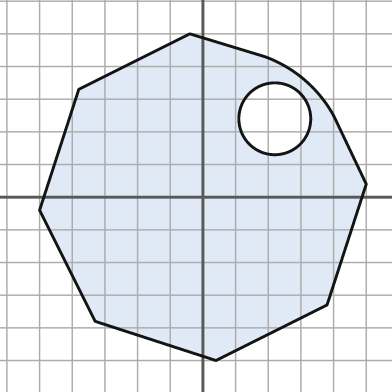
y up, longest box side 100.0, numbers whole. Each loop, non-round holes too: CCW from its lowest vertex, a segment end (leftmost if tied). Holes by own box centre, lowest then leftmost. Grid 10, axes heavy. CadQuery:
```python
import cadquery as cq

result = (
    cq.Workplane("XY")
    .moveTo(4.0, -50.0)
    .lineTo(38.0, -33.0)
    .lineTo(50.0, 4.0)
    .lineTo(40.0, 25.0)
    .threePointArc((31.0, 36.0), (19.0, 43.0))
    .lineTo(-4.0, 50.0)
    .lineTo(-38.0, 33.0)
    .lineTo(-50.0, -4.0)
    .lineTo(-33.0, -38.0)
    .close()
    .moveTo(22.0, 24.0)
    .circle(11.0)
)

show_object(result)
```